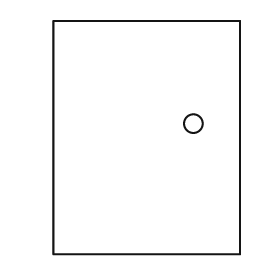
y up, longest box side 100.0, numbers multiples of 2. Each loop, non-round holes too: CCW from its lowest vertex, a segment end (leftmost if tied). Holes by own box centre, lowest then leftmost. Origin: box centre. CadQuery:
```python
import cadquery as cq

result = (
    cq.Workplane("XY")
    .moveTo(-40.0, -50.0)
    .lineTo(40.0, -50.0)
    .lineTo(40.0, 50.0)
    .lineTo(-40.0, 50.0)
    .close()
    .moveTo(20.0, 6.0)
    .circle(4.0)
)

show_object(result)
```